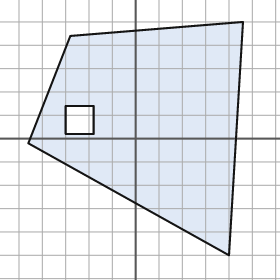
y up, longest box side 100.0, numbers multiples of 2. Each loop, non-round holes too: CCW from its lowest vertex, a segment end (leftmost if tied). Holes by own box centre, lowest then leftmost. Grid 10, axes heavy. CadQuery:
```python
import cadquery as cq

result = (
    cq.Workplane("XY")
    .moveTo(40.0, -50.0)
    .lineTo(46.0, 50.0)
    .lineTo(-28.0, 44.0)
    .lineTo(-46.0, -2.0)
    .close()
    .moveTo(-30.0, 2.0)
    .lineTo(-18.0, 2.0)
    .lineTo(-18.0, 14.0)
    .lineTo(-30.0, 14.0)
    .close()
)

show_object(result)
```